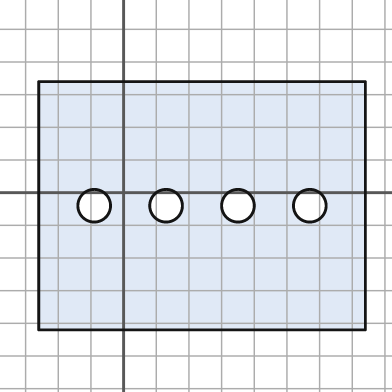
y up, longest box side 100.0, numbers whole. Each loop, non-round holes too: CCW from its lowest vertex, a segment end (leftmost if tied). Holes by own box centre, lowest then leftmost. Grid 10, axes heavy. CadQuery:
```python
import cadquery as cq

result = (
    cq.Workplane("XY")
    .moveTo(-26.0, -42.0)
    .lineTo(74.0, -42.0)
    .lineTo(74.0, 34.0)
    .lineTo(-26.0, 34.0)
    .close()
    .moveTo(-9.0, -4.0)
    .circle(5.0)
    .moveTo(13.0, -4.0)
    .circle(5.0)
    .moveTo(35.0, -4.0)
    .circle(5.0)
    .moveTo(57.0, -4.0)
    .circle(5.0)
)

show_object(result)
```